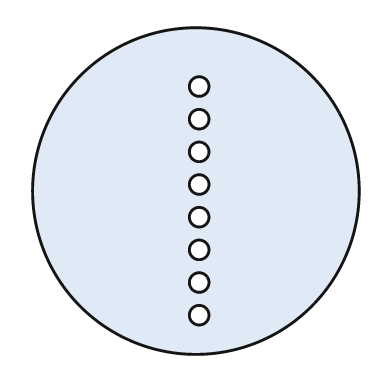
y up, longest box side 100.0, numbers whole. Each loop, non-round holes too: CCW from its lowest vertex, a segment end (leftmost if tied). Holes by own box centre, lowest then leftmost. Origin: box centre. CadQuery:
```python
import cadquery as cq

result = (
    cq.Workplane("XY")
    .moveTo(0.0, 0.0)
    .circle(50.0)
    .moveTo(1.0, -38.0)
    .circle(3.0)
    .moveTo(1.0, -28.0)
    .circle(3.0)
    .moveTo(1.0, -18.0)
    .circle(3.0)
    .moveTo(1.0, -8.0)
    .circle(3.0)
    .moveTo(1.0, 2.0)
    .circle(3.0)
    .moveTo(1.0, 12.0)
    .circle(3.0)
    .moveTo(1.0, 22.0)
    .circle(3.0)
    .moveTo(1.0, 32.0)
    .circle(3.0)
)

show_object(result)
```